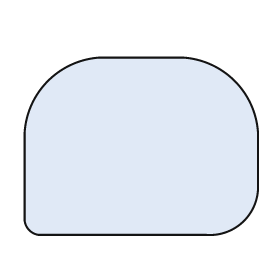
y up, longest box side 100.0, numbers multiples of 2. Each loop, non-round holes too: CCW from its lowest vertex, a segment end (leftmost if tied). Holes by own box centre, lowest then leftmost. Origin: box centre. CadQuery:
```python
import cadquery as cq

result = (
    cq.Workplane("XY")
    .moveTo(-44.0, -38.0)
    .lineTo(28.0, -38.0)
    .threePointArc((44.0, -32.0), (50.0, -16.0))
    .lineTo(50.0, 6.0)
    .threePointArc((40.0, 28.0), (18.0, 38.0))
    .lineTo(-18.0, 38.0)
    .threePointArc((-40.0, 28.0), (-50.0, 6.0))
    .lineTo(-50.0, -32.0)
    .threePointArc((-48.0, -36.0), (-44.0, -38.0))
    .close()
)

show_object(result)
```